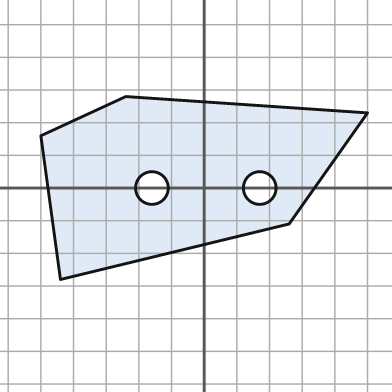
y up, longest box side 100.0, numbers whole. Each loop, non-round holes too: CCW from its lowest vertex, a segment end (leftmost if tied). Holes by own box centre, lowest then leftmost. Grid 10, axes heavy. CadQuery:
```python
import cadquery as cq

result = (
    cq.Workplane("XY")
    .moveTo(-44.0, -28.0)
    .lineTo(26.0, -11.0)
    .lineTo(50.0, 23.0)
    .lineTo(-24.0, 28.0)
    .lineTo(-50.0, 16.0)
    .close()
    .moveTo(-16.0, 0.0)
    .circle(5.0)
    .moveTo(17.0, 0.0)
    .circle(5.0)
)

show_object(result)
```